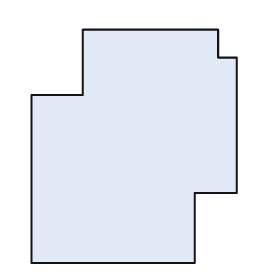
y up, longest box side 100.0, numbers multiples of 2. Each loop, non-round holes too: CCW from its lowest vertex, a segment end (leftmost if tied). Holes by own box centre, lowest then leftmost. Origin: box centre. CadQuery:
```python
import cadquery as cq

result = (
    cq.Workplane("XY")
    .moveTo(-44.0, -50.0)
    .lineTo(26.0, -50.0)
    .lineTo(26.0, -20.0)
    .lineTo(44.0, -20.0)
    .lineTo(44.0, 38.0)
    .lineTo(36.0, 38.0)
    .lineTo(36.0, 50.0)
    .lineTo(-22.0, 50.0)
    .lineTo(-22.0, 22.0)
    .lineTo(-44.0, 22.0)
    .close()
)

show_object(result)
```